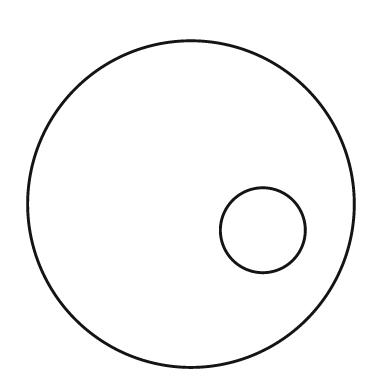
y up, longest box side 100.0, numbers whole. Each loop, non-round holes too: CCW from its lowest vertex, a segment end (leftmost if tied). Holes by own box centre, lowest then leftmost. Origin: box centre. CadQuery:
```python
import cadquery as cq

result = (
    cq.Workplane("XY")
    .moveTo(0.0, 0.0)
    .circle(50.0)
    .moveTo(22.0, -8.0)
    .circle(13.0)
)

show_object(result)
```